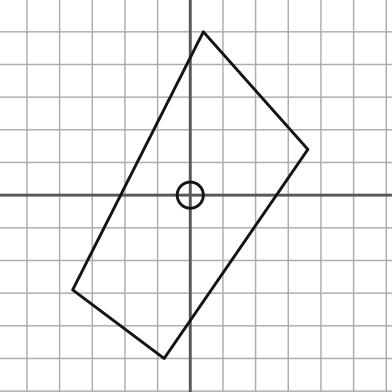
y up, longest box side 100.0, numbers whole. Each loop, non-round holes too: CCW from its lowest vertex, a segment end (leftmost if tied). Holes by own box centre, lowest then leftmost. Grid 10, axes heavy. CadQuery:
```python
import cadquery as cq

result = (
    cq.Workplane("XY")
    .moveTo(-8.0, -50.0)
    .lineTo(36.0, 14.0)
    .lineTo(4.0, 50.0)
    .lineTo(-36.0, -29.0)
    .close()
    .moveTo(0.0, 0.0)
    .circle(4.0)
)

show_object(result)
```